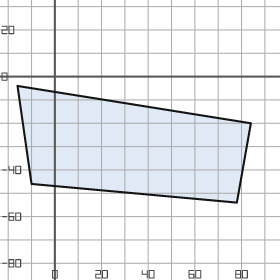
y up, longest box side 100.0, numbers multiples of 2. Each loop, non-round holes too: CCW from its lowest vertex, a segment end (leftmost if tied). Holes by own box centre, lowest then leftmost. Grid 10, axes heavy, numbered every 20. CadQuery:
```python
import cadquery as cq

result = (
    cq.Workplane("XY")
    .moveTo(78.0, -54.0)
    .lineTo(84.0, -20.0)
    .lineTo(-16.0, -4.0)
    .lineTo(-10.0, -46.0)
    .close()
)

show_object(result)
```